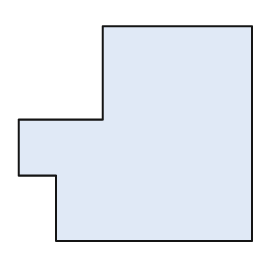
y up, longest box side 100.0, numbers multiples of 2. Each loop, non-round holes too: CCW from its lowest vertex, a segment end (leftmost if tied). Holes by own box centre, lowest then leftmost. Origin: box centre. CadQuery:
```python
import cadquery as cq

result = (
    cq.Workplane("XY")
    .moveTo(-34.0, -46.0)
    .lineTo(50.0, -46.0)
    .lineTo(50.0, 46.0)
    .lineTo(-14.0, 46.0)
    .lineTo(-14.0, 6.0)
    .lineTo(-50.0, 6.0)
    .lineTo(-50.0, -18.0)
    .lineTo(-34.0, -18.0)
    .close()
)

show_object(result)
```